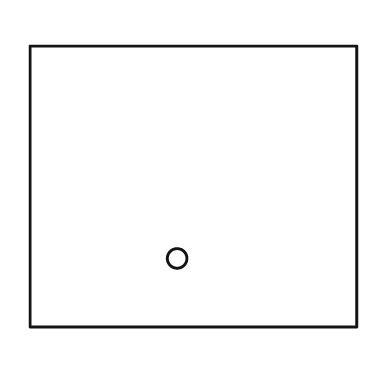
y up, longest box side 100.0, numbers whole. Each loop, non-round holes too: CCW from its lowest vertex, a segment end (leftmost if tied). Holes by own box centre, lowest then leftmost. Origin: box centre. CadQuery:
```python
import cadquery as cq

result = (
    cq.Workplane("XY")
    .moveTo(-50.0, -43.0)
    .lineTo(50.0, -43.0)
    .lineTo(50.0, 43.0)
    .lineTo(-50.0, 43.0)
    .close()
    .moveTo(-5.0, -22.0)
    .circle(3.0)
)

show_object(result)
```